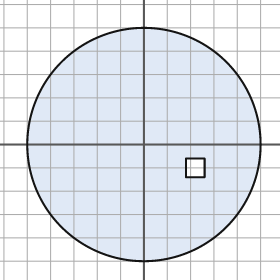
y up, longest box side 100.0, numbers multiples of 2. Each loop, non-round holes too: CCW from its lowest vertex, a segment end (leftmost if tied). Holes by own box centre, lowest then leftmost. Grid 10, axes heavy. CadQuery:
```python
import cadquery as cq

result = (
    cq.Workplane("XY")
    .moveTo(0.0, 0.0)
    .circle(50.0)
    .moveTo(18.0, -14.0)
    .lineTo(26.0, -14.0)
    .lineTo(26.0, -6.0)
    .lineTo(18.0, -6.0)
    .close()
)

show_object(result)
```